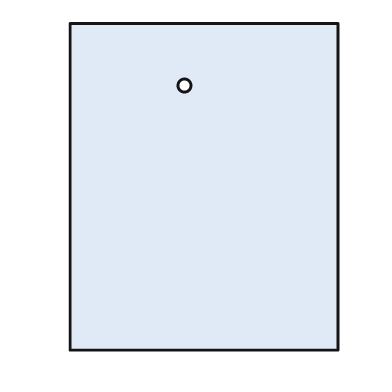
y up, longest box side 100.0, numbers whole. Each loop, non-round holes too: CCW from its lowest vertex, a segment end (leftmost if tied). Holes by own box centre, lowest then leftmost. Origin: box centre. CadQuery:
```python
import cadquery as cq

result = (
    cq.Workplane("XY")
    .moveTo(-41.0, -50.0)
    .lineTo(41.0, -50.0)
    .lineTo(41.0, 50.0)
    .lineTo(-41.0, 50.0)
    .close()
    .moveTo(-6.0, 31.0)
    .circle(2.0)
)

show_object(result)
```